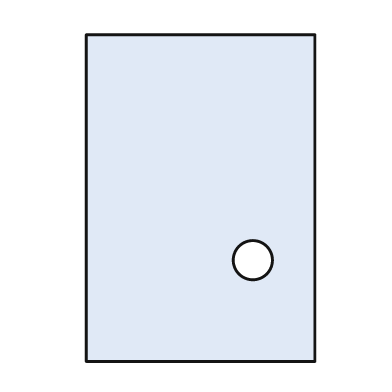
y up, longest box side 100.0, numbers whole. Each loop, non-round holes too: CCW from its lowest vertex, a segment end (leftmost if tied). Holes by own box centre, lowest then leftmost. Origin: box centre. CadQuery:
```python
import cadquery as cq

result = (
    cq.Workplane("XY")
    .moveTo(-35.0, -50.0)
    .lineTo(35.0, -50.0)
    .lineTo(35.0, 50.0)
    .lineTo(-35.0, 50.0)
    .close()
    .moveTo(16.0, -19.0)
    .circle(6.0)
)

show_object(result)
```